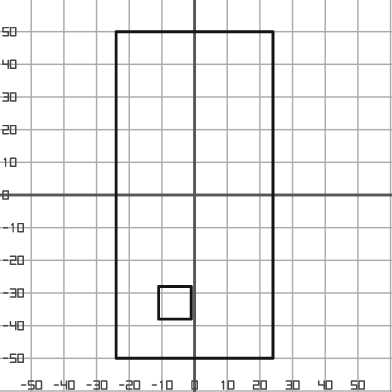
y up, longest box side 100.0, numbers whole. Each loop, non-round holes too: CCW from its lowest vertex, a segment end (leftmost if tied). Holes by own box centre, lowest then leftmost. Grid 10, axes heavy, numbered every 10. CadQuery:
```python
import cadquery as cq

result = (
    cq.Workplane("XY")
    .moveTo(-24.0, -50.0)
    .lineTo(24.0, -50.0)
    .lineTo(24.0, 50.0)
    .lineTo(-24.0, 50.0)
    .close()
    .moveTo(-11.0, -38.0)
    .lineTo(-1.0, -38.0)
    .lineTo(-1.0, -28.0)
    .lineTo(-11.0, -28.0)
    .close()
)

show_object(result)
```